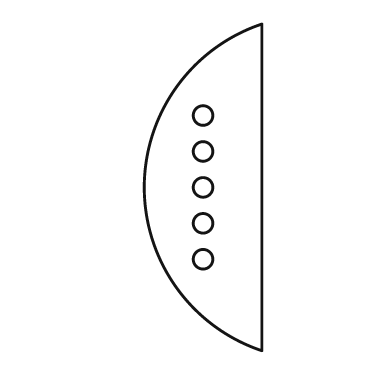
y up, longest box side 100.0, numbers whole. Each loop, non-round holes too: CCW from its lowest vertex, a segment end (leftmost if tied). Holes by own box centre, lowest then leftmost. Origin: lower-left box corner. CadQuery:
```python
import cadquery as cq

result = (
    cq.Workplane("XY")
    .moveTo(36.0, 0.0)
    .lineTo(36.0, 100.0)
    .threePointArc((0.0, 50.0), (36.0, 0.0))
    .close()
    .moveTo(18.0, 28.0)
    .circle(3.0)
    .moveTo(18.0, 39.0)
    .circle(3.0)
    .moveTo(18.0, 50.0)
    .circle(3.0)
    .moveTo(18.0, 61.0)
    .circle(3.0)
    .moveTo(18.0, 72.0)
    .circle(3.0)
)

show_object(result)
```